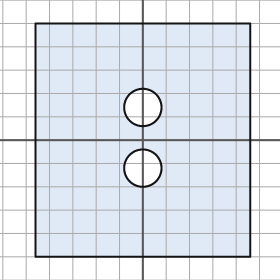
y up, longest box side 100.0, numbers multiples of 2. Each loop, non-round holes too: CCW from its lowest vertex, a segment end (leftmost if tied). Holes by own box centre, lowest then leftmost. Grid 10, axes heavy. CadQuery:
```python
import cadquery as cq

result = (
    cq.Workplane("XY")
    .moveTo(-46.0, -50.0)
    .lineTo(46.0, -50.0)
    .lineTo(46.0, 50.0)
    .lineTo(-46.0, 50.0)
    .close()
    .moveTo(0.0, -12.0)
    .circle(8.0)
    .moveTo(0.0, 14.0)
    .circle(8.0)
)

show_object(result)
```